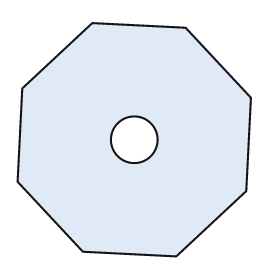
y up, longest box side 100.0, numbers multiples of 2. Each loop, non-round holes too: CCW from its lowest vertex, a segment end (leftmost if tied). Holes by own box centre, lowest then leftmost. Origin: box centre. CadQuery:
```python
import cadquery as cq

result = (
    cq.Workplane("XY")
    .moveTo(18.0, -50.0)
    .lineTo(48.0, -22.0)
    .lineTo(50.0, 18.0)
    .lineTo(22.0, 48.0)
    .lineTo(-18.0, 50.0)
    .lineTo(-48.0, 22.0)
    .lineTo(-50.0, -18.0)
    .lineTo(-22.0, -48.0)
    .close()
    .moveTo(0.0, 0.0)
    .circle(10.0)
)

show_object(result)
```